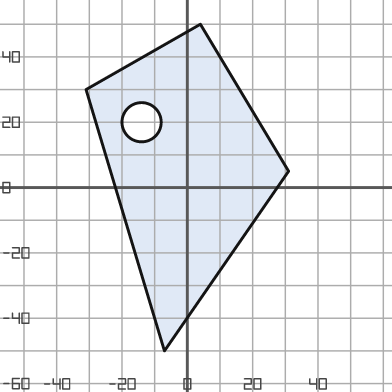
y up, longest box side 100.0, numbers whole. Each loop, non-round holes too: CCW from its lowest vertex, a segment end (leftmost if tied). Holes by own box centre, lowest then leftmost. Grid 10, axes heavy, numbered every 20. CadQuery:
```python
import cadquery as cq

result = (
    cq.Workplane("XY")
    .moveTo(-7.0, -50.0)
    .lineTo(31.0, 5.0)
    .lineTo(4.0, 50.0)
    .lineTo(-31.0, 30.0)
    .close()
    .moveTo(-14.0, 20.0)
    .circle(6.0)
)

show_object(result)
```